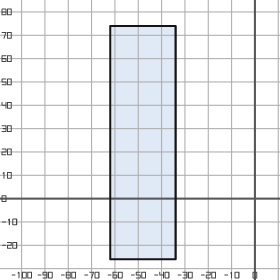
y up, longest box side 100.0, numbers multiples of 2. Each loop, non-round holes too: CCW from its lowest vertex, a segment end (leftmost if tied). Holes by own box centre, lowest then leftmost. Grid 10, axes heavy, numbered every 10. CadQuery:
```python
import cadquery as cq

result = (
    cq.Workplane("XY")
    .moveTo(-62.0, -26.0)
    .lineTo(-34.0, -26.0)
    .lineTo(-34.0, 74.0)
    .lineTo(-62.0, 74.0)
    .close()
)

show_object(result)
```